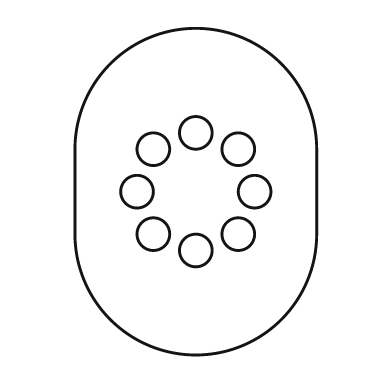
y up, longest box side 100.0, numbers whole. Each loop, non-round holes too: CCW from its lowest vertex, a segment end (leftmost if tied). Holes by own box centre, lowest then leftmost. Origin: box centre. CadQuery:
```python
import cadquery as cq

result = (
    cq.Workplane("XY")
    .moveTo(-37.0, -13.0)
    .threePointArc((0.0, -50.0), (37.0, -13.0))
    .lineTo(37.0, 13.0)
    .threePointArc((0.0, 50.0), (-37.0, 13.0))
    .close()
    .moveTo(0.0, -18.0)
    .circle(5.0)
    .moveTo(-13.0, -13.0)
    .circle(5.0)
    .moveTo(13.0, -13.0)
    .circle(5.0)
    .moveTo(-18.0, 0.0)
    .circle(5.0)
    .moveTo(18.0, 0.0)
    .circle(5.0)
    .moveTo(-13.0, 13.0)
    .circle(5.0)
    .moveTo(13.0, 13.0)
    .circle(5.0)
    .moveTo(0.0, 18.0)
    .circle(5.0)
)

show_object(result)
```